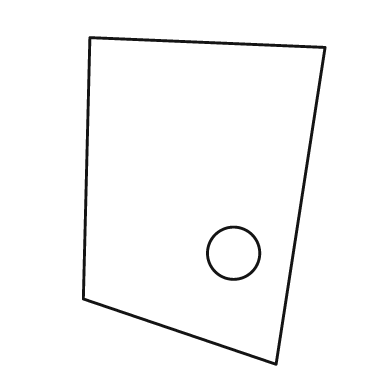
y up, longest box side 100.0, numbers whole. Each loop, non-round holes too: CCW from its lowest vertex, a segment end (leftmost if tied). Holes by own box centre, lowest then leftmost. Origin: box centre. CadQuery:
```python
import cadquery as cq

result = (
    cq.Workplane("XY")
    .moveTo(22.0, -50.0)
    .lineTo(37.0, 47.0)
    .lineTo(-35.0, 50.0)
    .lineTo(-37.0, -30.0)
    .close()
    .moveTo(9.0, -16.0)
    .circle(8.0)
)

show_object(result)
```